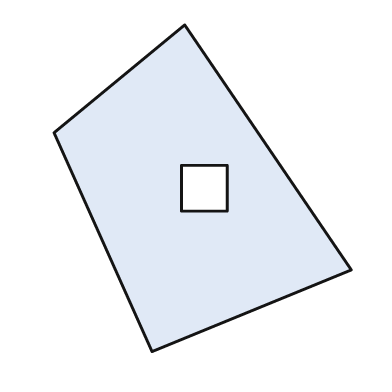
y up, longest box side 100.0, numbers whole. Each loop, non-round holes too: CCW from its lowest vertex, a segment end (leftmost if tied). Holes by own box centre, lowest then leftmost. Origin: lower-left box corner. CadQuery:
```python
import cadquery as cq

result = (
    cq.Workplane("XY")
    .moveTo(30.0, 0.0)
    .lineTo(91.0, 25.0)
    .lineTo(40.0, 100.0)
    .lineTo(0.0, 67.0)
    .close()
    .moveTo(39.0, 43.0)
    .lineTo(53.0, 43.0)
    .lineTo(53.0, 57.0)
    .lineTo(39.0, 57.0)
    .close()
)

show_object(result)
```